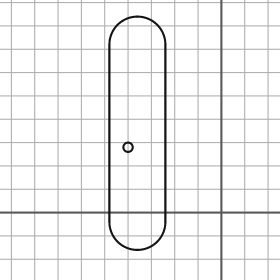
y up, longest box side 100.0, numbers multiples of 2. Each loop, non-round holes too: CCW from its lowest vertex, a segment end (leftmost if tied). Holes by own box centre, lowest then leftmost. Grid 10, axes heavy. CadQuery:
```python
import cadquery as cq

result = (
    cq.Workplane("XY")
    .moveTo(-48.0, -4.0)
    .threePointArc((-36.0, -16.0), (-24.0, -4.0))
    .lineTo(-24.0, 72.0)
    .threePointArc((-36.0, 84.0), (-48.0, 72.0))
    .close()
    .moveTo(-40.0, 28.0)
    .circle(2.0)
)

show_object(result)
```